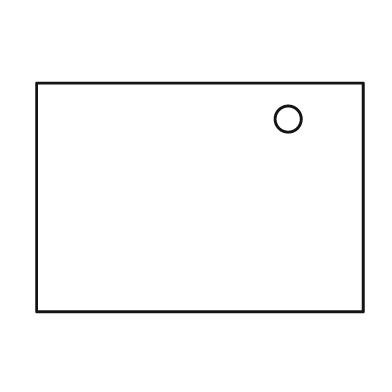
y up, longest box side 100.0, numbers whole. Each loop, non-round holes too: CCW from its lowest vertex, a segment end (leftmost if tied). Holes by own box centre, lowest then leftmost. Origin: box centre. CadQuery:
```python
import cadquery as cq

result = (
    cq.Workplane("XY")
    .moveTo(-50.0, -35.0)
    .lineTo(50.0, -35.0)
    .lineTo(50.0, 35.0)
    .lineTo(-50.0, 35.0)
    .close()
    .moveTo(27.0, 24.0)
    .circle(4.0)
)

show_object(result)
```